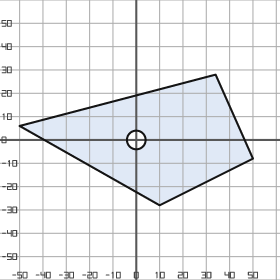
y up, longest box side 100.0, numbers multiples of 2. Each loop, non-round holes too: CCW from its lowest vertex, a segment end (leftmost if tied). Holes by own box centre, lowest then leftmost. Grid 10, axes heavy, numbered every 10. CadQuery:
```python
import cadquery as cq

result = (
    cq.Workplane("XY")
    .moveTo(10.0, -28.0)
    .lineTo(50.0, -8.0)
    .lineTo(34.0, 28.0)
    .lineTo(-50.0, 6.0)
    .close()
    .moveTo(0.0, 0.0)
    .circle(4.0)
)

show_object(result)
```